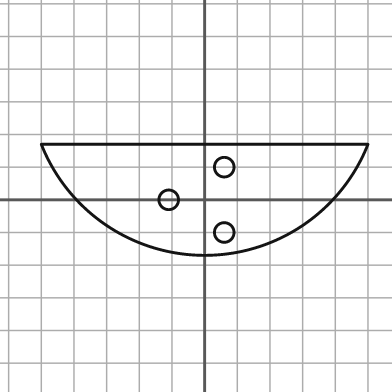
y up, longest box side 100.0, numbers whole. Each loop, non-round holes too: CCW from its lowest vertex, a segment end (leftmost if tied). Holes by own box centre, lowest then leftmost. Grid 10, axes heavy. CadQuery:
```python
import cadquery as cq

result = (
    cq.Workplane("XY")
    .moveTo(-50.0, 17.0)
    .threePointArc((0.0, -17.0), (50.0, 17.0))
    .close()
    .moveTo(6.0, -10.0)
    .circle(3.0)
    .moveTo(-11.0, 0.0)
    .circle(3.0)
    .moveTo(6.0, 10.0)
    .circle(3.0)
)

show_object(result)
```